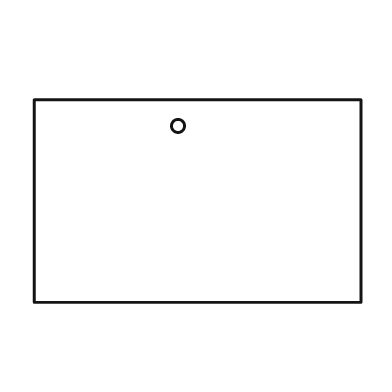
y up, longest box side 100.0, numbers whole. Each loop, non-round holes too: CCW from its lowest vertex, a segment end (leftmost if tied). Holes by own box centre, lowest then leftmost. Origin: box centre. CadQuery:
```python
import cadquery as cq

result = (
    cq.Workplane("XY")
    .moveTo(-50.0, -31.0)
    .lineTo(50.0, -31.0)
    .lineTo(50.0, 31.0)
    .lineTo(-50.0, 31.0)
    .close()
    .moveTo(-6.0, 23.0)
    .circle(2.0)
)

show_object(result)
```